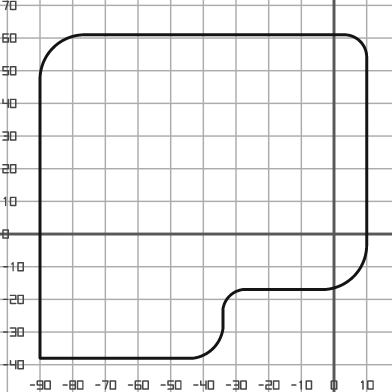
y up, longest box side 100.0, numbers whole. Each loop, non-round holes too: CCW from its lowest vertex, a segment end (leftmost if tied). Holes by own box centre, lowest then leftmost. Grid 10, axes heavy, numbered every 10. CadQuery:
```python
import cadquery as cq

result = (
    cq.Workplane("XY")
    .moveTo(-90.0, -38.0)
    .lineTo(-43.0, -38.0)
    .threePointArc((-37.0, -35.0), (-34.0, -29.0))
    .lineTo(-34.0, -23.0)
    .threePointArc((-32.0, -19.0), (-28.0, -17.0))
    .lineTo(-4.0, -17.0)
    .threePointArc((6.0, -13.0), (10.0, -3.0))
    .lineTo(10.0, 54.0)
    .threePointArc((8.0, 59.0), (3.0, 61.0))
    .lineTo(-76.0, 61.0)
    .threePointArc((-86.0, 57.0), (-90.0, 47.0))
    .close()
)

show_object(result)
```